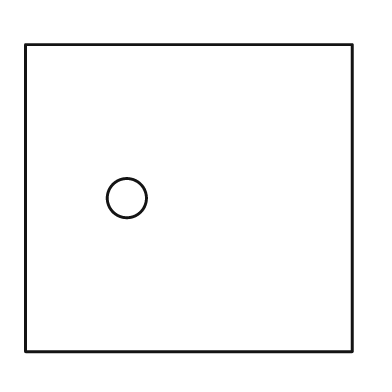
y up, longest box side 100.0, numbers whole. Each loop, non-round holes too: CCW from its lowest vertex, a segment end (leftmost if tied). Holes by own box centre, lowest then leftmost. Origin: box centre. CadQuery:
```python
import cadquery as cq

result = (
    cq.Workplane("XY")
    .moveTo(-50.0, -47.0)
    .lineTo(50.0, -47.0)
    .lineTo(50.0, 47.0)
    .lineTo(-50.0, 47.0)
    .close()
    .moveTo(-19.0, 0.0)
    .circle(6.0)
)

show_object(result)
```